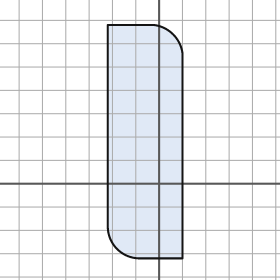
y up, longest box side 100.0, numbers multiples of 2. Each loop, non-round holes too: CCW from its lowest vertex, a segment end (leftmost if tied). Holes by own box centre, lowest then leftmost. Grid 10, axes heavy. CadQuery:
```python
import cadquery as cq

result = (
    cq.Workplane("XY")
    .moveTo(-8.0, -32.0)
    .lineTo(10.0, -32.0)
    .lineTo(10.0, 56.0)
    .threePointArc((6.0, 64.0), (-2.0, 68.0))
    .lineTo(-22.0, 68.0)
    .lineTo(-22.0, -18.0)
    .threePointArc((-18.0, -28.0), (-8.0, -32.0))
    .close()
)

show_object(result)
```